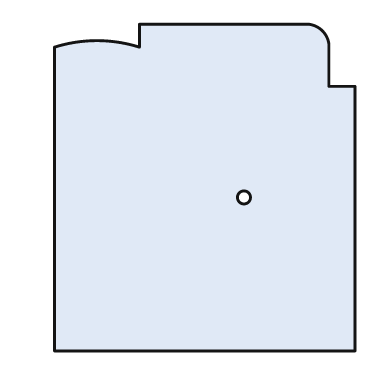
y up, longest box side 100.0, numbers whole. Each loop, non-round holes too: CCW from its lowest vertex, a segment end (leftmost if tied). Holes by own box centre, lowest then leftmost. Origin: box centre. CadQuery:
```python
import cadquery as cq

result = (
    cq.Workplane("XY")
    .moveTo(-46.0, -50.0)
    .lineTo(46.0, -50.0)
    .lineTo(46.0, 31.0)
    .lineTo(38.0, 31.0)
    .lineTo(38.0, 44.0)
    .threePointArc((36.0, 48.0), (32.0, 50.0))
    .lineTo(-20.0, 50.0)
    .lineTo(-20.0, 43.0)
    .threePointArc((-33.0, 45.0), (-46.0, 43.0))
    .close()
    .moveTo(12.0, -3.0)
    .circle(2.0)
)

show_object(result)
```